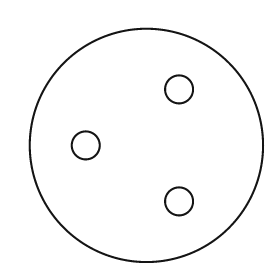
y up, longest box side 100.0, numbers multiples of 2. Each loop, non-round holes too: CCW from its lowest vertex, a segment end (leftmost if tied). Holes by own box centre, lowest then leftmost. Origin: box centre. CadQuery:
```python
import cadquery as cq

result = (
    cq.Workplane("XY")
    .moveTo(0.0, 0.0)
    .circle(50.0)
    .moveTo(14.0, -24.0)
    .circle(6.0)
    .moveTo(-26.0, 0.0)
    .circle(6.0)
    .moveTo(14.0, 24.0)
    .circle(6.0)
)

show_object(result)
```